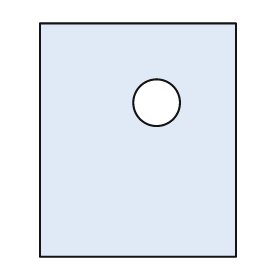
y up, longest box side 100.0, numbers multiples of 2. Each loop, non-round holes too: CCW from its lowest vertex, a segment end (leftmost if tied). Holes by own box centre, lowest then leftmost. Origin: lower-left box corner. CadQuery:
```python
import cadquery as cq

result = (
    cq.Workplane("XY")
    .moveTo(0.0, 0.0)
    .lineTo(84.0, 0.0)
    .lineTo(84.0, 100.0)
    .lineTo(0.0, 100.0)
    .close()
    .moveTo(50.0, 66.0)
    .circle(10.0)
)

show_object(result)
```